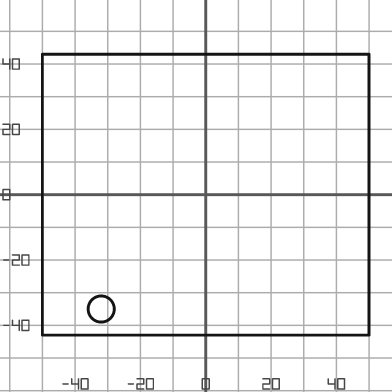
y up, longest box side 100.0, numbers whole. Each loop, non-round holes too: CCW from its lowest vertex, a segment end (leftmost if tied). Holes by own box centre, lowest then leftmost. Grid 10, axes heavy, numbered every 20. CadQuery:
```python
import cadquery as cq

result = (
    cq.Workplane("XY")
    .moveTo(-50.0, -43.0)
    .lineTo(50.0, -43.0)
    .lineTo(50.0, 43.0)
    .lineTo(-50.0, 43.0)
    .close()
    .moveTo(-32.0, -35.0)
    .circle(4.0)
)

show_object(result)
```